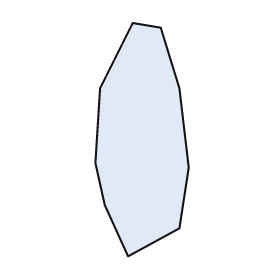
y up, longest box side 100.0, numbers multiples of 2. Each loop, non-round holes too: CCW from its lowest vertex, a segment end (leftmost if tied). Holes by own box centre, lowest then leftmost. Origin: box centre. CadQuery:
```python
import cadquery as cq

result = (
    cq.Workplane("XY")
    .moveTo(-6.0, -50.0)
    .lineTo(16.0, -38.0)
    .lineTo(20.0, -12.0)
    .lineTo(16.0, 22.0)
    .lineTo(8.0, 48.0)
    .lineTo(-4.0, 50.0)
    .lineTo(-18.0, 22.0)
    .lineTo(-20.0, -10.0)
    .lineTo(-16.0, -28.0)
    .close()
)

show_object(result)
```